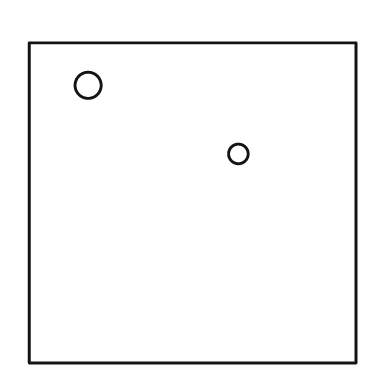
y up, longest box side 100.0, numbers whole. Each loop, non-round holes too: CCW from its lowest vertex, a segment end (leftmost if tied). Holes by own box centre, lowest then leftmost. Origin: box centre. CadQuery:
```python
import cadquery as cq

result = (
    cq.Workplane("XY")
    .moveTo(-50.0, -49.0)
    .lineTo(50.0, -49.0)
    .lineTo(50.0, 49.0)
    .lineTo(-50.0, 49.0)
    .close()
    .moveTo(14.0, 15.0)
    .circle(3.0)
    .moveTo(-32.0, 36.0)
    .circle(4.0)
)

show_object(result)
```